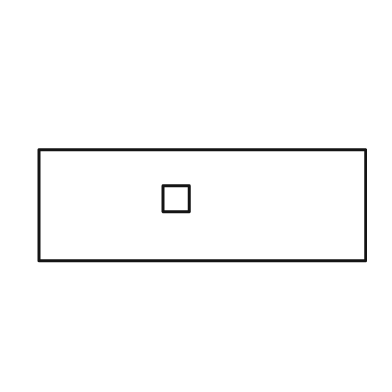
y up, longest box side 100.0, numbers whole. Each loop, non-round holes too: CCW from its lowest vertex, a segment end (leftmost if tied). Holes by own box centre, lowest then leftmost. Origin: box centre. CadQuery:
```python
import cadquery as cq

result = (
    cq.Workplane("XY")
    .moveTo(-50.0, -17.0)
    .lineTo(50.0, -17.0)
    .lineTo(50.0, 17.0)
    .lineTo(-50.0, 17.0)
    .close()
    .moveTo(-12.0, -2.0)
    .lineTo(-4.0, -2.0)
    .lineTo(-4.0, 6.0)
    .lineTo(-12.0, 6.0)
    .close()
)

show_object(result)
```